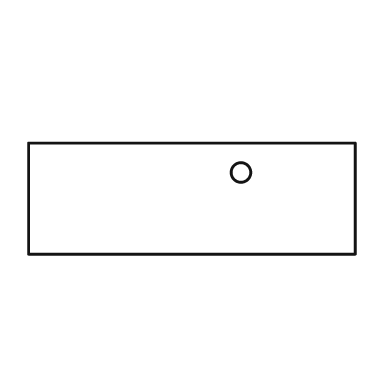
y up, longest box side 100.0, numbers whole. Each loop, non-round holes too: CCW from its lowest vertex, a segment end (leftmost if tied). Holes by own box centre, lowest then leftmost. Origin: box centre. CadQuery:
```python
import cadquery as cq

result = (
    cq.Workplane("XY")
    .moveTo(-50.0, -17.0)
    .lineTo(50.0, -17.0)
    .lineTo(50.0, 17.0)
    .lineTo(-50.0, 17.0)
    .close()
    .moveTo(15.0, 8.0)
    .circle(3.0)
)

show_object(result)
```